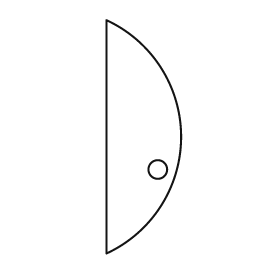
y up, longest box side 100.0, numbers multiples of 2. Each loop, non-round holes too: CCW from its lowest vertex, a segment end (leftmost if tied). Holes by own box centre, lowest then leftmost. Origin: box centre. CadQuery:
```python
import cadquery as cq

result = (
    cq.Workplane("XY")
    .moveTo(-16.0, -50.0)
    .threePointArc((16.0, 0.0), (-16.0, 50.0))
    .close()
    .moveTo(6.0, -14.0)
    .circle(4.0)
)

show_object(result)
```